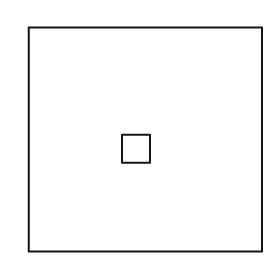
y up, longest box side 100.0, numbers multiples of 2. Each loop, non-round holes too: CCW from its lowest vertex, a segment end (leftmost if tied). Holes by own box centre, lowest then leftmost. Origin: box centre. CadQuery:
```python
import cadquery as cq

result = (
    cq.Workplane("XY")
    .moveTo(-50.0, -48.0)
    .lineTo(50.0, -48.0)
    .lineTo(50.0, 48.0)
    .lineTo(-50.0, 48.0)
    .close()
    .moveTo(-10.0, -10.0)
    .lineTo(2.0, -10.0)
    .lineTo(2.0, 2.0)
    .lineTo(-10.0, 2.0)
    .close()
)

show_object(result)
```